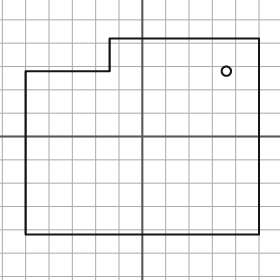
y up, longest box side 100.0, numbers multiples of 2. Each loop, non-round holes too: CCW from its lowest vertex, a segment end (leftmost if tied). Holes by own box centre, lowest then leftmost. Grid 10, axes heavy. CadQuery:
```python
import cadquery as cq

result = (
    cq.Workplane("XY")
    .moveTo(-50.0, -42.0)
    .lineTo(50.0, -42.0)
    .lineTo(50.0, 42.0)
    .lineTo(-14.0, 42.0)
    .lineTo(-14.0, 28.0)
    .lineTo(-50.0, 28.0)
    .close()
    .moveTo(36.0, 28.0)
    .circle(2.0)
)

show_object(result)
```